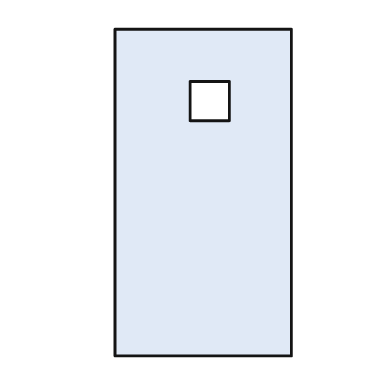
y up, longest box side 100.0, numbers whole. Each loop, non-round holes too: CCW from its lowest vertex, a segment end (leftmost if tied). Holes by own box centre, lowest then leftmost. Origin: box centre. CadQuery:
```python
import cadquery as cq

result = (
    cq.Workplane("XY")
    .moveTo(-27.0, -50.0)
    .lineTo(27.0, -50.0)
    .lineTo(27.0, 50.0)
    .lineTo(-27.0, 50.0)
    .close()
    .moveTo(-4.0, 22.0)
    .lineTo(8.0, 22.0)
    .lineTo(8.0, 34.0)
    .lineTo(-4.0, 34.0)
    .close()
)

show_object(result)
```